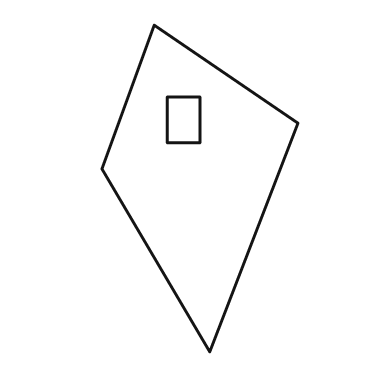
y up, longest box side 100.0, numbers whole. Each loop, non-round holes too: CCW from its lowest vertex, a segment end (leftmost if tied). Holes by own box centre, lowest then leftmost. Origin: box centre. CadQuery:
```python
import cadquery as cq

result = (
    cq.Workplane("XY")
    .moveTo(3.0, -50.0)
    .lineTo(30.0, 20.0)
    .lineTo(-14.0, 50.0)
    .lineTo(-30.0, 6.0)
    .close()
    .moveTo(-10.0, 14.0)
    .lineTo(0.0, 14.0)
    .lineTo(0.0, 28.0)
    .lineTo(-10.0, 28.0)
    .close()
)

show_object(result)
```